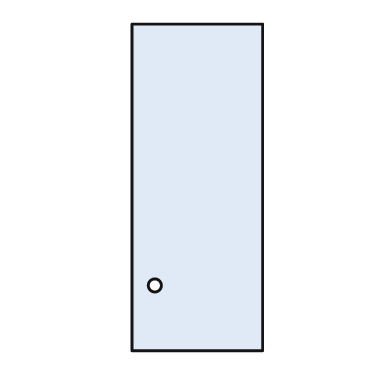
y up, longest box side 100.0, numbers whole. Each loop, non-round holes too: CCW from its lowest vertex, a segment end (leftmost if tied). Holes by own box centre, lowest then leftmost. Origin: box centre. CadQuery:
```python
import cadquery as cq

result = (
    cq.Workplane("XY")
    .moveTo(-20.0, -50.0)
    .lineTo(20.0, -50.0)
    .lineTo(20.0, 50.0)
    .lineTo(-20.0, 50.0)
    .close()
    .moveTo(-13.0, -30.0)
    .circle(2.0)
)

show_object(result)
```